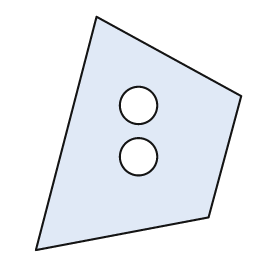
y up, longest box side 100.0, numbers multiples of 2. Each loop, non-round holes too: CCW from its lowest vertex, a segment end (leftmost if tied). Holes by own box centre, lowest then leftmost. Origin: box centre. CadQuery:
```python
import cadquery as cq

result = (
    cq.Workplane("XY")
    .moveTo(-44.0, -50.0)
    .lineTo(30.0, -36.0)
    .lineTo(44.0, 16.0)
    .lineTo(-18.0, 50.0)
    .close()
    .moveTo(0.0, -10.0)
    .circle(8.0)
    .moveTo(0.0, 12.0)
    .circle(8.0)
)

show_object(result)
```